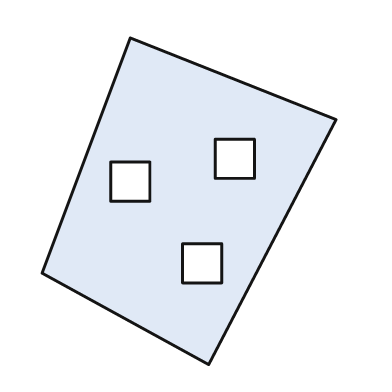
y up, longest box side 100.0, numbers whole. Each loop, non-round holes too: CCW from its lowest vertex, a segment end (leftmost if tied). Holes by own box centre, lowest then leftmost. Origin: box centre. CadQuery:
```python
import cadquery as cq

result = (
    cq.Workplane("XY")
    .moveTo(6.0, -50.0)
    .lineTo(45.0, 25.0)
    .lineTo(-18.0, 50.0)
    .lineTo(-45.0, -22.0)
    .close()
    .moveTo(-2.0, -25.0)
    .lineTo(10.0, -25.0)
    .lineTo(10.0, -13.0)
    .lineTo(-2.0, -13.0)
    .close()
    .moveTo(-24.0, 0.0)
    .lineTo(-12.0, 0.0)
    .lineTo(-12.0, 12.0)
    .lineTo(-24.0, 12.0)
    .close()
    .moveTo(8.0, 7.0)
    .lineTo(20.0, 7.0)
    .lineTo(20.0, 19.0)
    .lineTo(8.0, 19.0)
    .close()
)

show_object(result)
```